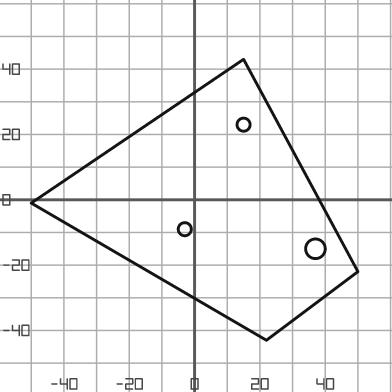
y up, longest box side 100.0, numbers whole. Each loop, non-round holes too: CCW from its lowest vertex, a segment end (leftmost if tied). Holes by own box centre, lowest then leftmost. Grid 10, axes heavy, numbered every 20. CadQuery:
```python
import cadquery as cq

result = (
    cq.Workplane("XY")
    .moveTo(22.0, -43.0)
    .lineTo(50.0, -22.0)
    .lineTo(15.0, 43.0)
    .lineTo(-50.0, -1.0)
    .close()
    .moveTo(37.0, -15.0)
    .circle(3.0)
    .moveTo(-3.0, -9.0)
    .circle(2.0)
    .moveTo(15.0, 23.0)
    .circle(2.0)
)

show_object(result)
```